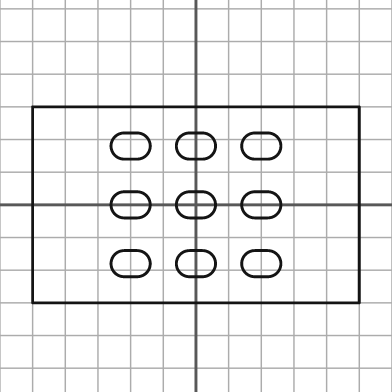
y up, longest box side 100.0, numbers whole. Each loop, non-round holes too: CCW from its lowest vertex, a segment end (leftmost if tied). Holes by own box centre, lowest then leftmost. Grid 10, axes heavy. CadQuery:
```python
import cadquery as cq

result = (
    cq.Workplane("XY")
    .moveTo(-50.0, -30.0)
    .lineTo(50.0, -30.0)
    .lineTo(50.0, 30.0)
    .lineTo(-50.0, 30.0)
    .close()
    .moveTo(-22.0, -22.0)
    .lineTo(-18.0, -22.0)
    .threePointArc((-14.0, -18.0), (-18.0, -14.0))
    .lineTo(-22.0, -14.0)
    .threePointArc((-26.0, -18.0), (-22.0, -22.0))
    .close()
    .moveTo(-2.0, -22.0)
    .lineTo(2.0, -22.0)
    .threePointArc((6.0, -18.0), (2.0, -14.0))
    .lineTo(-2.0, -14.0)
    .threePointArc((-6.0, -18.0), (-2.0, -22.0))
    .close()
    .moveTo(18.0, -22.0)
    .lineTo(22.0, -22.0)
    .threePointArc((26.0, -18.0), (22.0, -14.0))
    .lineTo(18.0, -14.0)
    .threePointArc((14.0, -18.0), (18.0, -22.0))
    .close()
    .moveTo(-22.0, -4.0)
    .lineTo(-18.0, -4.0)
    .threePointArc((-14.0, 0.0), (-18.0, 4.0))
    .lineTo(-22.0, 4.0)
    .threePointArc((-26.0, 0.0), (-22.0, -4.0))
    .close()
    .moveTo(-2.0, -4.0)
    .lineTo(2.0, -4.0)
    .threePointArc((6.0, 0.0), (2.0, 4.0))
    .lineTo(-2.0, 4.0)
    .threePointArc((-6.0, 0.0), (-2.0, -4.0))
    .close()
    .moveTo(18.0, -4.0)
    .lineTo(22.0, -4.0)
    .threePointArc((26.0, 0.0), (22.0, 4.0))
    .lineTo(18.0, 4.0)
    .threePointArc((14.0, 0.0), (18.0, -4.0))
    .close()
    .moveTo(-22.0, 14.0)
    .lineTo(-18.0, 14.0)
    .threePointArc((-14.0, 18.0), (-18.0, 22.0))
    .lineTo(-22.0, 22.0)
    .threePointArc((-26.0, 18.0), (-22.0, 14.0))
    .close()
    .moveTo(-2.0, 14.0)
    .lineTo(2.0, 14.0)
    .threePointArc((6.0, 18.0), (2.0, 22.0))
    .lineTo(-2.0, 22.0)
    .threePointArc((-6.0, 18.0), (-2.0, 14.0))
    .close()
    .moveTo(18.0, 14.0)
    .lineTo(22.0, 14.0)
    .threePointArc((26.0, 18.0), (22.0, 22.0))
    .lineTo(18.0, 22.0)
    .threePointArc((14.0, 18.0), (18.0, 14.0))
    .close()
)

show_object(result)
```